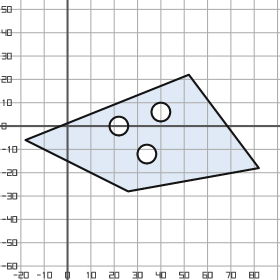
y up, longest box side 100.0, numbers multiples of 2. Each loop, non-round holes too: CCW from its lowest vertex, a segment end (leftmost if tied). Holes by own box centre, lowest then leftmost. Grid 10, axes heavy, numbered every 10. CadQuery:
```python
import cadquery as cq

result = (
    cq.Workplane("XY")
    .moveTo(26.0, -28.0)
    .lineTo(82.0, -18.0)
    .lineTo(52.0, 22.0)
    .lineTo(-18.0, -6.0)
    .close()
    .moveTo(34.0, -12.0)
    .circle(4.0)
    .moveTo(22.0, 0.0)
    .circle(4.0)
    .moveTo(40.0, 6.0)
    .circle(4.0)
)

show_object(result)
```